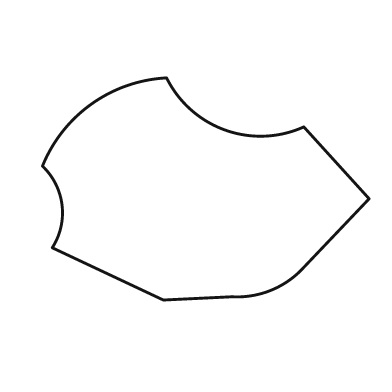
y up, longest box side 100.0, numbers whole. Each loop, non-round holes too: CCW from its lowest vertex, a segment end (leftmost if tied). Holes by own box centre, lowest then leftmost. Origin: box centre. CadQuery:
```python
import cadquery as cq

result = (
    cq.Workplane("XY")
    .moveTo(-13.0, -34.0)
    .lineTo(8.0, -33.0)
    .threePointArc((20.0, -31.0), (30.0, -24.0))
    .lineTo(50.0, -3.0)
    .lineTo(30.0, 19.0)
    .threePointArc((6.0, 18.0), (-12.0, 34.0))
    .threePointArc((-35.0, 26.0), (-50.0, 7.0))
    .threePointArc((-44.0, -5.0), (-47.0, -18.0))
    .close()
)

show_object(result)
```